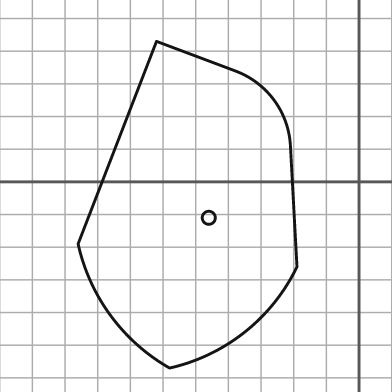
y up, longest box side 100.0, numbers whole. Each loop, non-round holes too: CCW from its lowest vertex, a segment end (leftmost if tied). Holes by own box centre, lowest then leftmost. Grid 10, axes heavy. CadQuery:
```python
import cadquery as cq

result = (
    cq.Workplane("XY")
    .moveTo(-58.0, -57.0)
    .threePointArc((-35.0, -46.0), (-19.0, -26.0))
    .lineTo(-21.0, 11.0)
    .threePointArc((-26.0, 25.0), (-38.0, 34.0))
    .lineTo(-62.0, 43.0)
    .lineTo(-86.0, -19.0)
    .threePointArc((-76.0, -41.0), (-58.0, -57.0))
    .close()
    .moveTo(-46.0, -11.0)
    .circle(2.0)
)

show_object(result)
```